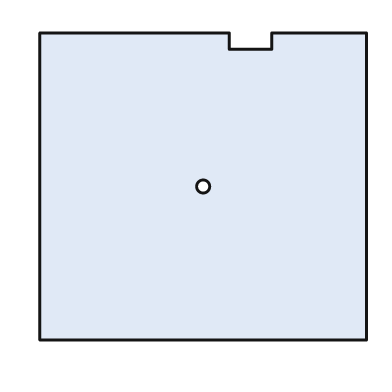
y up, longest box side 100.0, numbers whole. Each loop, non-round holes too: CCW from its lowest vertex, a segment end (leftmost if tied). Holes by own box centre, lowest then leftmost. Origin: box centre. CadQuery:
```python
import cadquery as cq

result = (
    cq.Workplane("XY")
    .moveTo(-50.0, -47.0)
    .lineTo(50.0, -47.0)
    .lineTo(50.0, 47.0)
    .lineTo(21.0, 47.0)
    .lineTo(21.0, 42.0)
    .lineTo(8.0, 42.0)
    .lineTo(8.0, 47.0)
    .lineTo(-50.0, 47.0)
    .close()
    .moveTo(0.0, 0.0)
    .circle(2.0)
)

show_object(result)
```